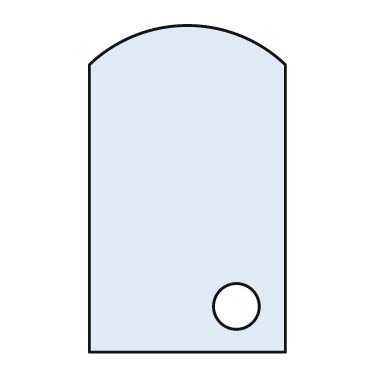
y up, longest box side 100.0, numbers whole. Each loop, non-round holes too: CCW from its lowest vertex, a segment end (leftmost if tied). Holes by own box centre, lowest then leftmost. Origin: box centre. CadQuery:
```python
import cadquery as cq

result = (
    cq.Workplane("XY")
    .moveTo(-30.0, -50.0)
    .lineTo(30.0, -50.0)
    .lineTo(30.0, 38.0)
    .threePointArc((0.0, 50.0), (-30.0, 38.0))
    .close()
    .moveTo(15.0, -36.0)
    .circle(7.0)
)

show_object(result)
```